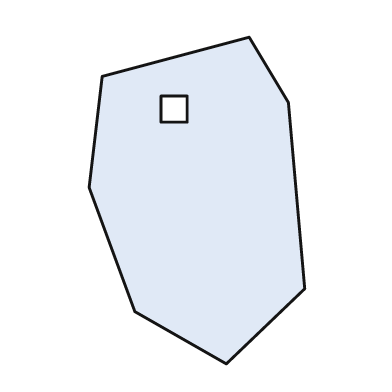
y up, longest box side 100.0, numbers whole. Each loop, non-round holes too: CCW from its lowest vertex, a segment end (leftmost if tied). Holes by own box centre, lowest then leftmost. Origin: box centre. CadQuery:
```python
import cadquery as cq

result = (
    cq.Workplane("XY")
    .moveTo(9.0, -50.0)
    .lineTo(33.0, -27.0)
    .lineTo(28.0, 30.0)
    .lineTo(16.0, 50.0)
    .lineTo(-29.0, 38.0)
    .lineTo(-33.0, 4.0)
    .lineTo(-19.0, -34.0)
    .close()
    .moveTo(-11.0, 24.0)
    .lineTo(-3.0, 24.0)
    .lineTo(-3.0, 32.0)
    .lineTo(-11.0, 32.0)
    .close()
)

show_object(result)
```